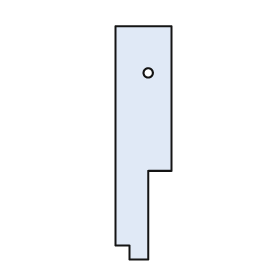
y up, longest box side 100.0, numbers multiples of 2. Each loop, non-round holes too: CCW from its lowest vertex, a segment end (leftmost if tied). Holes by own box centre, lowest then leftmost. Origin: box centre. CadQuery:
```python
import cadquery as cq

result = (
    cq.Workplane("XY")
    .moveTo(-6.0, -50.0)
    .lineTo(2.0, -50.0)
    .lineTo(2.0, -12.0)
    .lineTo(12.0, -12.0)
    .lineTo(12.0, 50.0)
    .lineTo(-12.0, 50.0)
    .lineTo(-12.0, -44.0)
    .lineTo(-6.0, -44.0)
    .close()
    .moveTo(2.0, 30.0)
    .circle(2.0)
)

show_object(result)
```